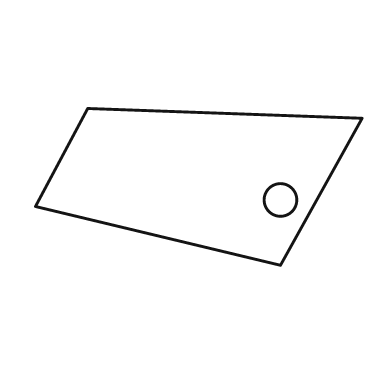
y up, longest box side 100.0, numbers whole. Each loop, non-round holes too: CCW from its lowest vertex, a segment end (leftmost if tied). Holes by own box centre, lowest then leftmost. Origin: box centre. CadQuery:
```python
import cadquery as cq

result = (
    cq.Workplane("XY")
    .moveTo(25.0, -24.0)
    .lineTo(50.0, 21.0)
    .lineTo(-34.0, 24.0)
    .lineTo(-50.0, -6.0)
    .close()
    .moveTo(25.0, -4.0)
    .circle(5.0)
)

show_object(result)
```